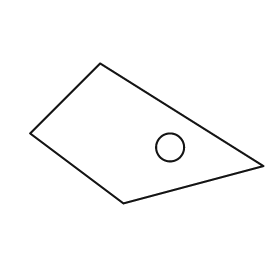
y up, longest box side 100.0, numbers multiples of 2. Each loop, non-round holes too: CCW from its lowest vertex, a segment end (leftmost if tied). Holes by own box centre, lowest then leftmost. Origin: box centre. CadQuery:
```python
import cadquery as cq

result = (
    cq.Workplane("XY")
    .moveTo(-10.0, -30.0)
    .lineTo(50.0, -14.0)
    .lineTo(-20.0, 30.0)
    .lineTo(-50.0, 0.0)
    .close()
    .moveTo(10.0, -6.0)
    .circle(6.0)
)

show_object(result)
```